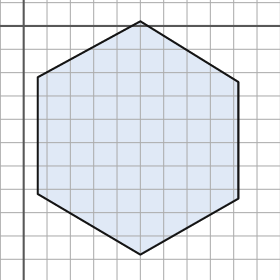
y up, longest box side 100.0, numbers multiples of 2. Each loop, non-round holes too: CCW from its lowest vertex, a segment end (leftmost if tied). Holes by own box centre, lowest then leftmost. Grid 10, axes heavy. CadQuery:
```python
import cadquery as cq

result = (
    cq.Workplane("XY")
    .moveTo(50.0, -98.0)
    .lineTo(92.0, -74.0)
    .lineTo(92.0, -24.0)
    .lineTo(50.0, 2.0)
    .lineTo(6.0, -22.0)
    .lineTo(6.0, -72.0)
    .close()
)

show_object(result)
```